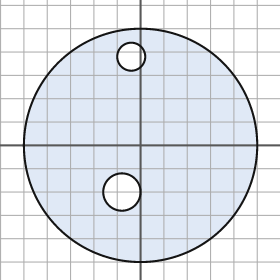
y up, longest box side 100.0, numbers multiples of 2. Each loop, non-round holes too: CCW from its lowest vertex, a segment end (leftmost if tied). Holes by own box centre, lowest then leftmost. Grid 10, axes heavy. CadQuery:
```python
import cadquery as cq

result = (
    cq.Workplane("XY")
    .moveTo(0.0, 0.0)
    .circle(50.0)
    .moveTo(-8.0, -20.0)
    .circle(8.0)
    .moveTo(-4.0, 38.0)
    .circle(6.0)
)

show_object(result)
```